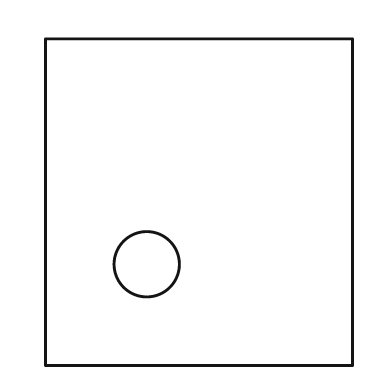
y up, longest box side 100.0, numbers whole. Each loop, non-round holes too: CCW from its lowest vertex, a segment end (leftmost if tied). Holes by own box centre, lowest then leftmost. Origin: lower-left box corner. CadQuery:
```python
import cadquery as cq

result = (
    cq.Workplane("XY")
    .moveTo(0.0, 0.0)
    .lineTo(94.0, 0.0)
    .lineTo(94.0, 100.0)
    .lineTo(0.0, 100.0)
    .close()
    .moveTo(31.0, 31.0)
    .circle(10.0)
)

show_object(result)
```